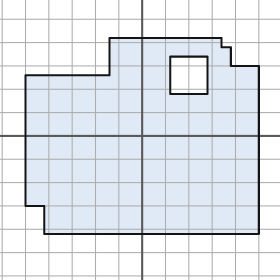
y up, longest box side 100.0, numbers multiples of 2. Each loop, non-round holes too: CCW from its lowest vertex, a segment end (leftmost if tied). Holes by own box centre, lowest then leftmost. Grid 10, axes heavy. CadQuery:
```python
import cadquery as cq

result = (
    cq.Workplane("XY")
    .moveTo(-42.0, -42.0)
    .lineTo(50.0, -42.0)
    .lineTo(50.0, 30.0)
    .lineTo(38.0, 30.0)
    .lineTo(38.0, 38.0)
    .lineTo(34.0, 38.0)
    .lineTo(34.0, 42.0)
    .lineTo(-14.0, 42.0)
    .lineTo(-14.0, 26.0)
    .lineTo(-50.0, 26.0)
    .lineTo(-50.0, -30.0)
    .lineTo(-42.0, -30.0)
    .close()
    .moveTo(12.0, 18.0)
    .lineTo(28.0, 18.0)
    .lineTo(28.0, 34.0)
    .lineTo(12.0, 34.0)
    .close()
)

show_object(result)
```